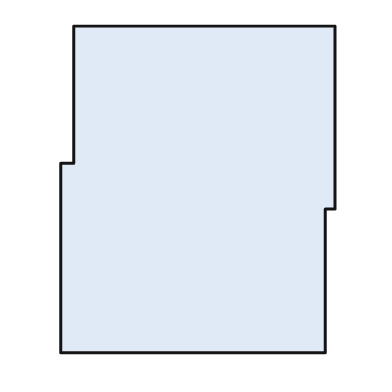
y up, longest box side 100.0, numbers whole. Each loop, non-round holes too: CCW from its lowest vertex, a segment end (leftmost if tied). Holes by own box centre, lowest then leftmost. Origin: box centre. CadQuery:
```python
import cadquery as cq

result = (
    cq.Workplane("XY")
    .moveTo(-42.0, -50.0)
    .lineTo(39.0, -50.0)
    .lineTo(39.0, -6.0)
    .lineTo(42.0, -6.0)
    .lineTo(42.0, 50.0)
    .lineTo(-38.0, 50.0)
    .lineTo(-38.0, 8.0)
    .lineTo(-42.0, 8.0)
    .close()
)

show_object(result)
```